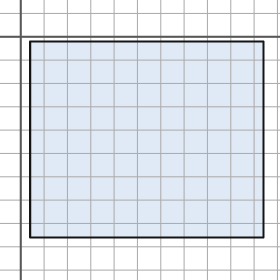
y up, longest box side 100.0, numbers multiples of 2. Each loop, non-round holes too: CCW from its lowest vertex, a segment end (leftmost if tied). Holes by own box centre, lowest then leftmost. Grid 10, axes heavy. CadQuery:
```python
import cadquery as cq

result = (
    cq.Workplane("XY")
    .moveTo(4.0, -86.0)
    .lineTo(104.0, -86.0)
    .lineTo(104.0, -2.0)
    .lineTo(4.0, -2.0)
    .close()
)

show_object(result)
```